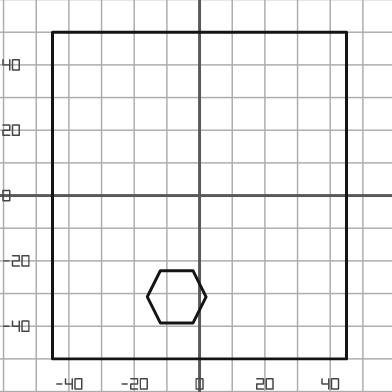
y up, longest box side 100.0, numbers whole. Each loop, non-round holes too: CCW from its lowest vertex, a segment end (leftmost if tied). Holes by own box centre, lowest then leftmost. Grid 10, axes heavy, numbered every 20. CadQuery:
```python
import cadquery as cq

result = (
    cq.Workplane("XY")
    .moveTo(-45.0, -50.0)
    .lineTo(45.0, -50.0)
    .lineTo(45.0, 50.0)
    .lineTo(-45.0, 50.0)
    .close()
    .moveTo(-12.0, -39.0)
    .lineTo(-2.0, -39.0)
    .lineTo(2.0, -31.0)
    .lineTo(-2.0, -23.0)
    .lineTo(-12.0, -23.0)
    .lineTo(-16.0, -31.0)
    .close()
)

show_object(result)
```